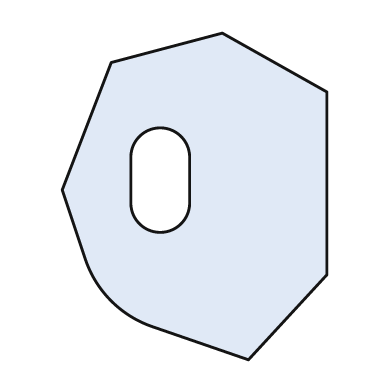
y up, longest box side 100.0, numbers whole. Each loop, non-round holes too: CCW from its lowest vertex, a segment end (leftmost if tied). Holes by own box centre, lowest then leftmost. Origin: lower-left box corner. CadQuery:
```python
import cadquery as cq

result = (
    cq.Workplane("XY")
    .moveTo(57.0, 0.0)
    .lineTo(81.0, 26.0)
    .lineTo(81.0, 82.0)
    .lineTo(49.0, 100.0)
    .lineTo(15.0, 91.0)
    .lineTo(0.0, 52.0)
    .lineTo(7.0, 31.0)
    .threePointArc((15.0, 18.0), (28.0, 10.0))
    .close()
    .moveTo(21.0, 48.0)
    .threePointArc((30.0, 39.0), (39.0, 48.0))
    .lineTo(39.0, 62.0)
    .threePointArc((30.0, 71.0), (21.0, 62.0))
    .close()
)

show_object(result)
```